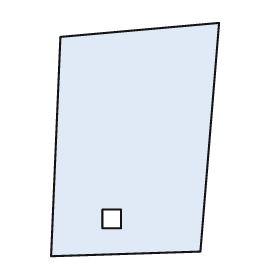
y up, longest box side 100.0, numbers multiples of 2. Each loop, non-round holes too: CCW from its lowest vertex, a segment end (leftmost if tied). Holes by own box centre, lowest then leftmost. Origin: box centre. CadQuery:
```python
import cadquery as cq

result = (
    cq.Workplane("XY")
    .moveTo(-36.0, -50.0)
    .lineTo(28.0, -48.0)
    .lineTo(36.0, 50.0)
    .lineTo(-32.0, 44.0)
    .close()
    .moveTo(-14.0, -38.0)
    .lineTo(-6.0, -38.0)
    .lineTo(-6.0, -30.0)
    .lineTo(-14.0, -30.0)
    .close()
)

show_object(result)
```